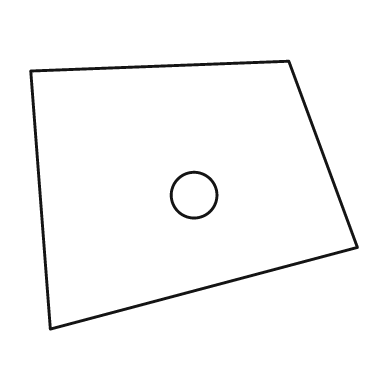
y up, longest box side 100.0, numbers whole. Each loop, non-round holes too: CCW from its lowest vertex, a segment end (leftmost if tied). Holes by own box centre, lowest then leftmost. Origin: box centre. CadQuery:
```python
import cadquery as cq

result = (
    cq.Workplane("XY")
    .moveTo(-44.0, -41.0)
    .lineTo(50.0, -16.0)
    .lineTo(29.0, 41.0)
    .lineTo(-50.0, 38.0)
    .close()
    .moveTo(0.0, 0.0)
    .circle(7.0)
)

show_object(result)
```